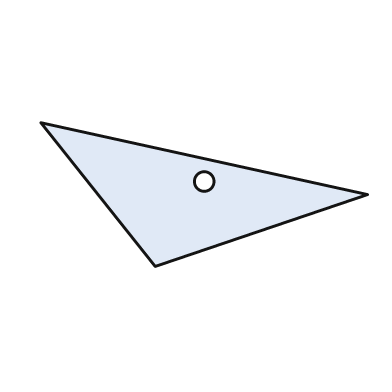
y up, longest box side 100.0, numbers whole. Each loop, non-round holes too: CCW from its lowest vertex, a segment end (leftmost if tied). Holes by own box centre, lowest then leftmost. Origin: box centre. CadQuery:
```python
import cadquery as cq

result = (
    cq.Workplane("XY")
    .moveTo(-15.0, -22.0)
    .lineTo(50.0, 0.0)
    .lineTo(-50.0, 22.0)
    .close()
    .moveTo(0.0, 4.0)
    .circle(3.0)
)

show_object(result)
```